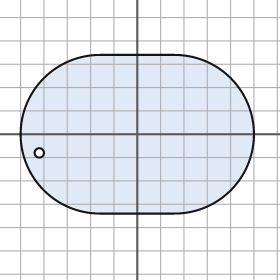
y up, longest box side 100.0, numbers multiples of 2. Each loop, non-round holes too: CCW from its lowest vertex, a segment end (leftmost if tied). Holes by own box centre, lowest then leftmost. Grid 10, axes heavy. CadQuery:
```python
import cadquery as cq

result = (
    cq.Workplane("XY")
    .moveTo(-16.0, -34.0)
    .lineTo(16.0, -34.0)
    .threePointArc((50.0, 0.0), (16.0, 34.0))
    .lineTo(-16.0, 34.0)
    .threePointArc((-50.0, 0.0), (-16.0, -34.0))
    .close()
    .moveTo(-42.0, -8.0)
    .circle(2.0)
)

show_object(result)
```